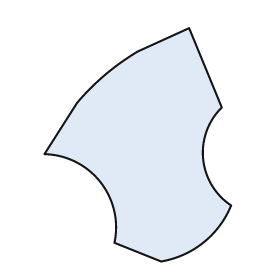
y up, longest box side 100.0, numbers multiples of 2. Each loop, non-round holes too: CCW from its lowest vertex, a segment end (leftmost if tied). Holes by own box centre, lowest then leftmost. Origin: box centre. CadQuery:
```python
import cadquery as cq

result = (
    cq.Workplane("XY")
    .moveTo(10.0, -50.0)
    .threePointArc((28.0, -42.0), (40.0, -26.0))
    .threePointArc((28.0, -6.0), (36.0, 16.0))
    .lineTo(22.0, 50.0)
    .lineTo(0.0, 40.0)
    .threePointArc((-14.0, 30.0), (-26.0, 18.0))
    .lineTo(-40.0, -4.0)
    .threePointArc((-16.0, -16.0), (-10.0, -42.0))
    .close()
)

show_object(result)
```